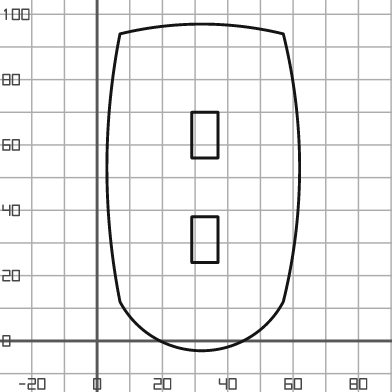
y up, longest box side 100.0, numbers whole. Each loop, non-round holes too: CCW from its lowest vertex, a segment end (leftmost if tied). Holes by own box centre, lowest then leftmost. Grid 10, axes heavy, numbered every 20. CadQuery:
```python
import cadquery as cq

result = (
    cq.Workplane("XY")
    .moveTo(7.0, 12.0)
    .threePointArc((32.0, -3.0), (57.0, 12.0))
    .threePointArc((62.0, 53.0), (57.0, 94.0))
    .threePointArc((32.0, 97.0), (7.0, 94.0))
    .threePointArc((3.0, 53.0), (7.0, 12.0))
    .close()
    .moveTo(29.0, 24.0)
    .lineTo(37.0, 24.0)
    .lineTo(37.0, 38.0)
    .lineTo(29.0, 38.0)
    .close()
    .moveTo(29.0, 56.0)
    .lineTo(37.0, 56.0)
    .lineTo(37.0, 70.0)
    .lineTo(29.0, 70.0)
    .close()
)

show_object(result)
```